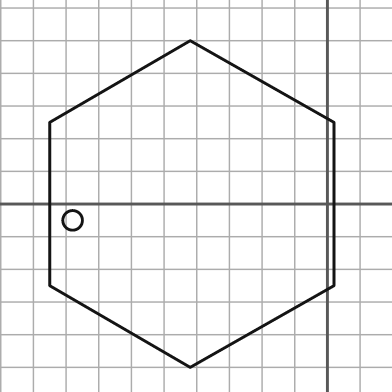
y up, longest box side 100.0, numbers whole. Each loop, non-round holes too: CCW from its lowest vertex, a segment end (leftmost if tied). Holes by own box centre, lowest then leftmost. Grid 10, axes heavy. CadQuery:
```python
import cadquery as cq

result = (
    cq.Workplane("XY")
    .moveTo(-42.0, -50.0)
    .lineTo(2.0, -25.0)
    .lineTo(2.0, 25.0)
    .lineTo(-42.0, 50.0)
    .lineTo(-85.0, 25.0)
    .lineTo(-85.0, -25.0)
    .close()
    .moveTo(-78.0, -5.0)
    .circle(3.0)
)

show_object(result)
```